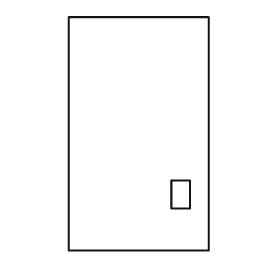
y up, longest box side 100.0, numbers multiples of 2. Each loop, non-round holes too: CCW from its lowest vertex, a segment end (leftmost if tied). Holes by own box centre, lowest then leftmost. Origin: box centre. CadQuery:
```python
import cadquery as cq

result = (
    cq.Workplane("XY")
    .moveTo(-30.0, -50.0)
    .lineTo(30.0, -50.0)
    .lineTo(30.0, 50.0)
    .lineTo(-30.0, 50.0)
    .close()
    .moveTo(14.0, -32.0)
    .lineTo(22.0, -32.0)
    .lineTo(22.0, -20.0)
    .lineTo(14.0, -20.0)
    .close()
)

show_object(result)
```